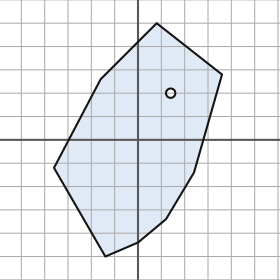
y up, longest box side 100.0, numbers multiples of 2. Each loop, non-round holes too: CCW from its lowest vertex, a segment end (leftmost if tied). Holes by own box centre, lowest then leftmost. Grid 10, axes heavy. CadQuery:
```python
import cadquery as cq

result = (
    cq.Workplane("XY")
    .moveTo(-14.0, -50.0)
    .lineTo(0.0, -44.0)
    .lineTo(12.0, -34.0)
    .lineTo(24.0, -14.0)
    .lineTo(36.0, 28.0)
    .lineTo(8.0, 50.0)
    .lineTo(-16.0, 26.0)
    .lineTo(-36.0, -12.0)
    .close()
    .moveTo(14.0, 20.0)
    .circle(2.0)
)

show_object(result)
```